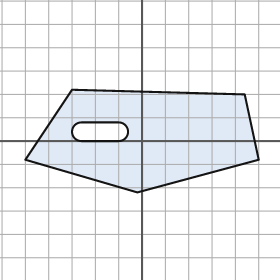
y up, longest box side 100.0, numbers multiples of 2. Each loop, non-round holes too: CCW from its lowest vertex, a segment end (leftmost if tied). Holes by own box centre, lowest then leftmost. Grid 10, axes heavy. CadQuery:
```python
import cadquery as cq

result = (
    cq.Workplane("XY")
    .moveTo(-2.0, -22.0)
    .lineTo(50.0, -8.0)
    .lineTo(44.0, 20.0)
    .lineTo(-30.0, 22.0)
    .lineTo(-50.0, -8.0)
    .close()
    .moveTo(-26.0, 0.0)
    .lineTo(-10.0, 0.0)
    .threePointArc((-6.0, 4.0), (-10.0, 8.0))
    .lineTo(-26.0, 8.0)
    .threePointArc((-30.0, 4.0), (-26.0, 0.0))
    .close()
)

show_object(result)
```